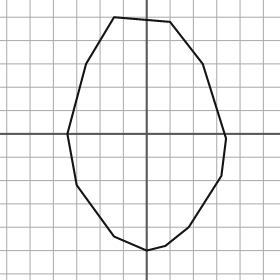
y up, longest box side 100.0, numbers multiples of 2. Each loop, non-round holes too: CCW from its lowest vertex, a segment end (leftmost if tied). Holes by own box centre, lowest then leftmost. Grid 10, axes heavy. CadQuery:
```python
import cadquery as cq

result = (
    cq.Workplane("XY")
    .moveTo(0.0, -50.0)
    .lineTo(8.0, -48.0)
    .lineTo(18.0, -40.0)
    .lineTo(32.0, -18.0)
    .lineTo(34.0, -2.0)
    .lineTo(24.0, 30.0)
    .lineTo(10.0, 48.0)
    .lineTo(-14.0, 50.0)
    .lineTo(-26.0, 30.0)
    .lineTo(-34.0, 0.0)
    .lineTo(-30.0, -22.0)
    .lineTo(-14.0, -44.0)
    .close()
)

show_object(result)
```